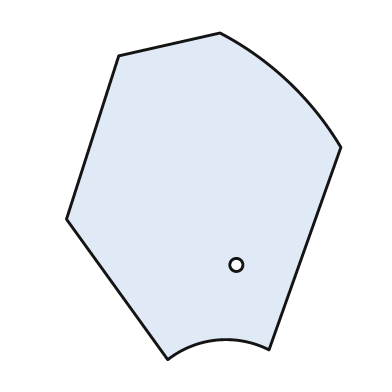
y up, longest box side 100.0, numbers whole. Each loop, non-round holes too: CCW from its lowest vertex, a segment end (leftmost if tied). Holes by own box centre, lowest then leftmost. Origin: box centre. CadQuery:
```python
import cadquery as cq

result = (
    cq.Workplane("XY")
    .moveTo(-11.0, -50.0)
    .threePointArc((4.0, -44.0), (20.0, -47.0))
    .lineTo(42.0, 15.0)
    .threePointArc((26.0, 35.0), (5.0, 50.0))
    .lineTo(-26.0, 43.0)
    .lineTo(-42.0, -7.0)
    .close()
    .moveTo(10.0, -21.0)
    .circle(2.0)
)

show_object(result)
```